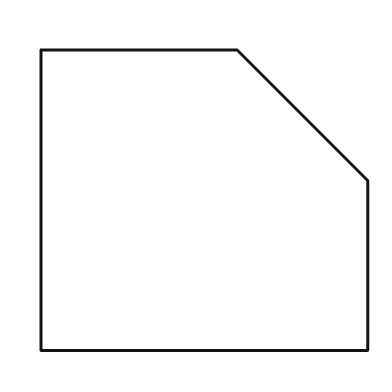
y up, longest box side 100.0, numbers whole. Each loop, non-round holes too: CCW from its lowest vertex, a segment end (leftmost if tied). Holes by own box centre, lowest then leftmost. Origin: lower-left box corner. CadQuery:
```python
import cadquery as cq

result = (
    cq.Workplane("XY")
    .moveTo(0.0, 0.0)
    .lineTo(100.0, 0.0)
    .lineTo(100.0, 52.0)
    .lineTo(60.0, 92.0)
    .lineTo(0.0, 92.0)
    .close()
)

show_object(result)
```